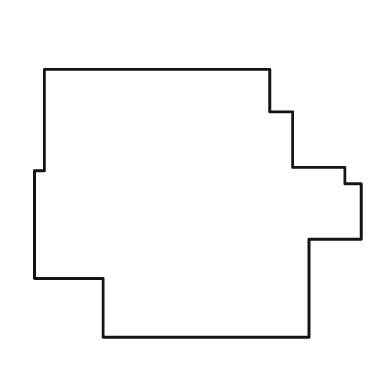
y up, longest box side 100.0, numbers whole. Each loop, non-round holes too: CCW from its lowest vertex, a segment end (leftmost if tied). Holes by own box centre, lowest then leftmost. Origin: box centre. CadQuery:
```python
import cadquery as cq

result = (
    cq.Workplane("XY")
    .moveTo(-29.0, -41.0)
    .lineTo(34.0, -41.0)
    .lineTo(34.0, -11.0)
    .lineTo(50.0, -11.0)
    .lineTo(50.0, 6.0)
    .lineTo(45.0, 6.0)
    .lineTo(45.0, 11.0)
    .lineTo(29.0, 11.0)
    .lineTo(29.0, 28.0)
    .lineTo(22.0, 28.0)
    .lineTo(22.0, 41.0)
    .lineTo(-47.0, 41.0)
    .lineTo(-47.0, 10.0)
    .lineTo(-50.0, 10.0)
    .lineTo(-50.0, -23.0)
    .lineTo(-29.0, -23.0)
    .close()
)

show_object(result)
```